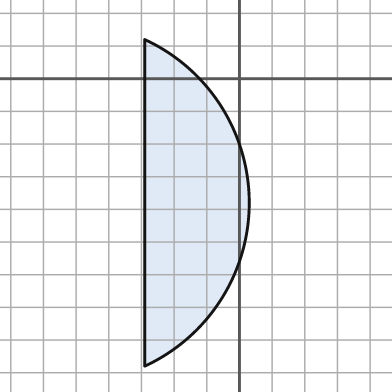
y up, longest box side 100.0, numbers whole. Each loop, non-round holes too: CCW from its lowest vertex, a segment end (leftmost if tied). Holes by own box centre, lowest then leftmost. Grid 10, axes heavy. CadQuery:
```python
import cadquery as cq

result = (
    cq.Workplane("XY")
    .moveTo(-29.0, -88.0)
    .threePointArc((3.0, -38.0), (-29.0, 12.0))
    .close()
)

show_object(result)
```